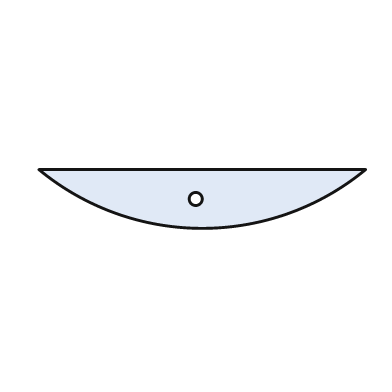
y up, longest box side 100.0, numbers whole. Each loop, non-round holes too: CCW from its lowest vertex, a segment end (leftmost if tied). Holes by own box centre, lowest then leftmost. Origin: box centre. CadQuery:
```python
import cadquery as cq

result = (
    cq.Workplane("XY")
    .moveTo(-50.0, 9.0)
    .threePointArc((0.0, -9.0), (50.0, 9.0))
    .close()
    .moveTo(-2.0, 0.0)
    .circle(2.0)
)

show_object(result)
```